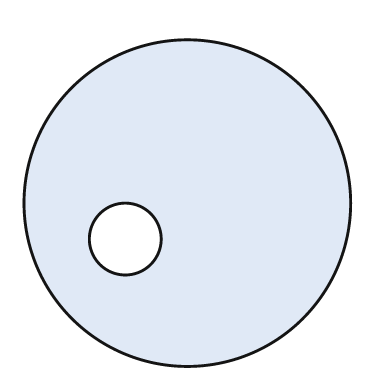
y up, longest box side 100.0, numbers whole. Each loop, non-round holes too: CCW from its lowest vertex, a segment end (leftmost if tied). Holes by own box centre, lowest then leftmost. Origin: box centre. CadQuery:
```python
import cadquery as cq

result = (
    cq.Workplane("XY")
    .moveTo(0.0, 0.0)
    .circle(50.0)
    .moveTo(-19.0, -11.0)
    .circle(11.0)
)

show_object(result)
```